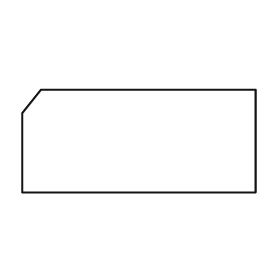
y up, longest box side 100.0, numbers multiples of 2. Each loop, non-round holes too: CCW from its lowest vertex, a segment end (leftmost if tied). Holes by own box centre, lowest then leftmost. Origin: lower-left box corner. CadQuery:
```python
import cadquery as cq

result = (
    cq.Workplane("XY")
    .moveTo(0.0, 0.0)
    .lineTo(100.0, 0.0)
    .lineTo(100.0, 44.0)
    .lineTo(8.0, 44.0)
    .lineTo(0.0, 34.0)
    .close()
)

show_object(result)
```